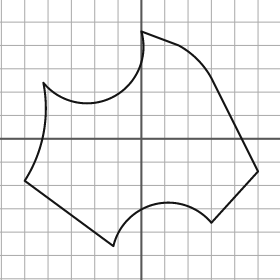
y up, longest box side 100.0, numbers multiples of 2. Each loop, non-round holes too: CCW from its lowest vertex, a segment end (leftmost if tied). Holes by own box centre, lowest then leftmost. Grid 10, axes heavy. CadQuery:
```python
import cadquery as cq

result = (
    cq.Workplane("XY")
    .moveTo(-12.0, -46.0)
    .threePointArc((6.0, -28.0), (30.0, -36.0))
    .lineTo(50.0, -14.0)
    .lineTo(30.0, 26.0)
    .threePointArc((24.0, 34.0), (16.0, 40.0))
    .lineTo(0.0, 46.0)
    .threePointArc((-12.0, 18.0), (-42.0, 24.0))
    .threePointArc((-42.0, 2.0), (-50.0, -18.0))
    .close()
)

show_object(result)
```